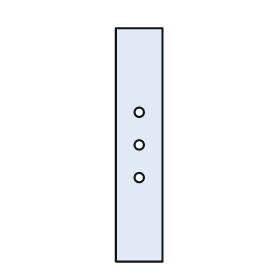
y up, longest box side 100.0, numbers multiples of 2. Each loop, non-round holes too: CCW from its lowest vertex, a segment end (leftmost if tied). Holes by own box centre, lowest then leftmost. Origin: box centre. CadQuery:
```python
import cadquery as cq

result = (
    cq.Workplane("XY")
    .moveTo(-10.0, -50.0)
    .lineTo(10.0, -50.0)
    .lineTo(10.0, 50.0)
    .lineTo(-10.0, 50.0)
    .close()
    .moveTo(0.0, -14.0)
    .circle(2.0)
    .moveTo(0.0, 0.0)
    .circle(2.0)
    .moveTo(0.0, 14.0)
    .circle(2.0)
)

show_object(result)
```